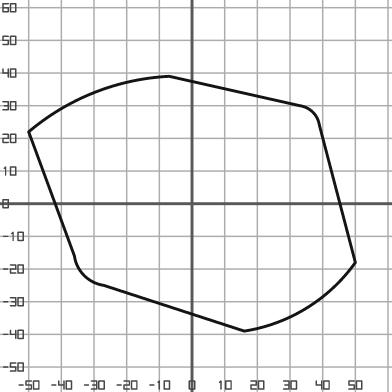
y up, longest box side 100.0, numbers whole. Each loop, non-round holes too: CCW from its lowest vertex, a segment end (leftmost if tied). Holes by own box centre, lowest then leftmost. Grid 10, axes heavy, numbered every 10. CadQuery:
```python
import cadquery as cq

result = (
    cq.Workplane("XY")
    .moveTo(16.0, -39.0)
    .threePointArc((35.0, -32.0), (50.0, -18.0))
    .lineTo(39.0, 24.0)
    .threePointArc((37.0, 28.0), (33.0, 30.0))
    .lineTo(-7.0, 39.0)
    .threePointArc((-30.0, 34.0), (-50.0, 22.0))
    .lineTo(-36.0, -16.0)
    .threePointArc((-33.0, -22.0), (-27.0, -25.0))
    .close()
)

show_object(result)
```